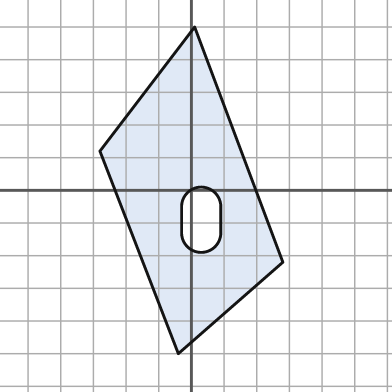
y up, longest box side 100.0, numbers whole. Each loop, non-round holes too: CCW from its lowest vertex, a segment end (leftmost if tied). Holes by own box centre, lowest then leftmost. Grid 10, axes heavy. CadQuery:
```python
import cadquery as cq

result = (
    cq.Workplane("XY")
    .moveTo(-4.0, -50.0)
    .lineTo(28.0, -22.0)
    .lineTo(1.0, 50.0)
    .lineTo(-28.0, 12.0)
    .close()
    .moveTo(-3.0, -13.0)
    .threePointArc((3.0, -19.0), (9.0, -13.0))
    .lineTo(9.0, -5.0)
    .threePointArc((3.0, 1.0), (-3.0, -5.0))
    .close()
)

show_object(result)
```